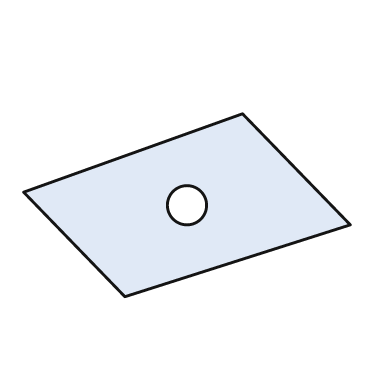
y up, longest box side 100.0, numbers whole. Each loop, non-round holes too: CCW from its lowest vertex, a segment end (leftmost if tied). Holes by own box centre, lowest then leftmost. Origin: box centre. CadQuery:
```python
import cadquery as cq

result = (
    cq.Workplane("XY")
    .moveTo(-19.0, -28.0)
    .lineTo(50.0, -6.0)
    .lineTo(17.0, 28.0)
    .lineTo(-50.0, 4.0)
    .close()
    .moveTo(0.0, 0.0)
    .circle(6.0)
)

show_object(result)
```